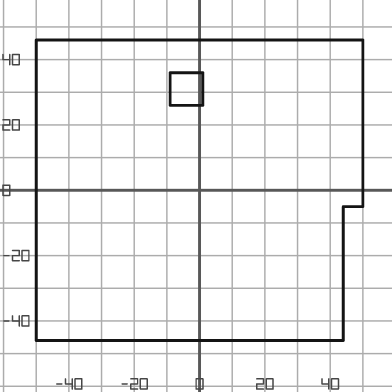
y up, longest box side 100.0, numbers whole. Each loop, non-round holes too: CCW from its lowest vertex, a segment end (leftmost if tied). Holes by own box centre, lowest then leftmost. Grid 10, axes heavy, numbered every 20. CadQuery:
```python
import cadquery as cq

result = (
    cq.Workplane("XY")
    .moveTo(-50.0, -46.0)
    .lineTo(44.0, -46.0)
    .lineTo(44.0, -5.0)
    .lineTo(50.0, -5.0)
    .lineTo(50.0, 46.0)
    .lineTo(-50.0, 46.0)
    .close()
    .moveTo(-9.0, 26.0)
    .lineTo(1.0, 26.0)
    .lineTo(1.0, 36.0)
    .lineTo(-9.0, 36.0)
    .close()
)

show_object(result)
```